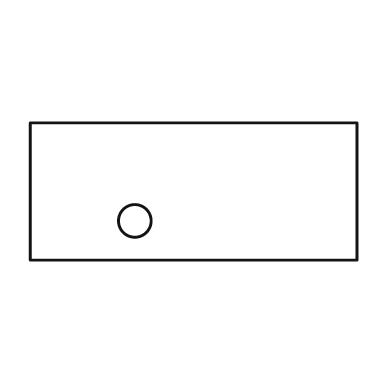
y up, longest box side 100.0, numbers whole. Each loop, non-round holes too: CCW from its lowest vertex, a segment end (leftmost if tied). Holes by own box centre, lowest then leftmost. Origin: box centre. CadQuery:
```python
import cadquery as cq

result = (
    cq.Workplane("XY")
    .moveTo(-50.0, -21.0)
    .lineTo(50.0, -21.0)
    .lineTo(50.0, 21.0)
    .lineTo(-50.0, 21.0)
    .close()
    .moveTo(-18.0, -9.0)
    .circle(5.0)
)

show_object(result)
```